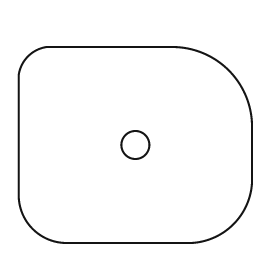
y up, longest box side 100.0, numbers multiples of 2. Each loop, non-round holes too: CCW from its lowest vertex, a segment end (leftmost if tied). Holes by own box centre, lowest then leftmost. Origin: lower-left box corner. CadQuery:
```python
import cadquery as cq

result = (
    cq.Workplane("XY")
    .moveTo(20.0, 0.0)
    .lineTo(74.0, 0.0)
    .threePointArc((92.0, 8.0), (100.0, 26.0))
    .lineTo(100.0, 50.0)
    .threePointArc((90.0, 74.0), (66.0, 84.0))
    .lineTo(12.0, 84.0)
    .threePointArc((4.0, 80.0), (0.0, 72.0))
    .lineTo(0.0, 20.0)
    .threePointArc((6.0, 6.0), (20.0, 0.0))
    .close()
    .moveTo(50.0, 42.0)
    .circle(6.0)
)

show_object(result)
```